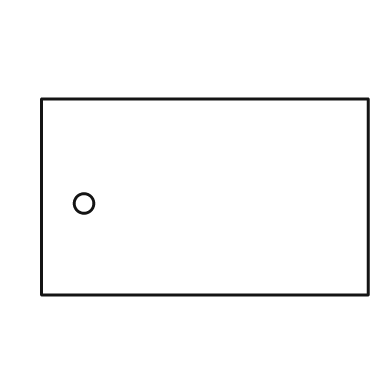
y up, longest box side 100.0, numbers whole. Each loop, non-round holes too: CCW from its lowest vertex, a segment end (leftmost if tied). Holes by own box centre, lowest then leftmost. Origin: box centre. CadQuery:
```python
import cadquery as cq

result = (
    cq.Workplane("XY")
    .moveTo(-50.0, -30.0)
    .lineTo(50.0, -30.0)
    .lineTo(50.0, 30.0)
    .lineTo(-50.0, 30.0)
    .close()
    .moveTo(-37.0, -2.0)
    .circle(3.0)
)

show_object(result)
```